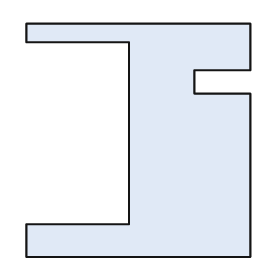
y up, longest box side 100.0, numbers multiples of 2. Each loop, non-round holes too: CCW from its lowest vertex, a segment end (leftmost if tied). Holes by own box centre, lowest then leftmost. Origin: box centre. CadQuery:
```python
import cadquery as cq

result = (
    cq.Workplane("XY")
    .moveTo(-48.0, -50.0)
    .lineTo(48.0, -50.0)
    .lineTo(48.0, 20.0)
    .lineTo(24.0, 20.0)
    .lineTo(24.0, 30.0)
    .lineTo(48.0, 30.0)
    .lineTo(48.0, 50.0)
    .lineTo(-48.0, 50.0)
    .lineTo(-48.0, 42.0)
    .lineTo(-4.0, 42.0)
    .lineTo(-4.0, -36.0)
    .lineTo(-48.0, -36.0)
    .close()
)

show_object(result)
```